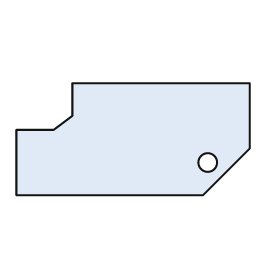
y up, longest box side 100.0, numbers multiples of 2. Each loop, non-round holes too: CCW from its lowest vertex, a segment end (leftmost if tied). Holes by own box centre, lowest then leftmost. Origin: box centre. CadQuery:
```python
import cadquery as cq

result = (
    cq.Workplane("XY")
    .moveTo(-50.0, -24.0)
    .lineTo(30.0, -24.0)
    .lineTo(50.0, -4.0)
    .lineTo(50.0, 24.0)
    .lineTo(-26.0, 24.0)
    .lineTo(-26.0, 10.0)
    .lineTo(-34.0, 4.0)
    .lineTo(-50.0, 4.0)
    .close()
    .moveTo(32.0, -10.0)
    .circle(4.0)
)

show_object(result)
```